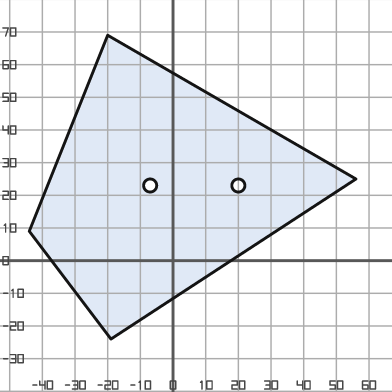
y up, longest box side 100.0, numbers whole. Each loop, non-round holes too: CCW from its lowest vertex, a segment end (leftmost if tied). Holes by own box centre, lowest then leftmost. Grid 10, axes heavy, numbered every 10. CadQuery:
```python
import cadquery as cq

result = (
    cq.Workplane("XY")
    .moveTo(-19.0, -24.0)
    .lineTo(56.0, 25.0)
    .lineTo(-20.0, 69.0)
    .lineTo(-44.0, 9.0)
    .close()
    .moveTo(-7.0, 23.0)
    .circle(2.0)
    .moveTo(20.0, 23.0)
    .circle(2.0)
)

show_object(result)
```